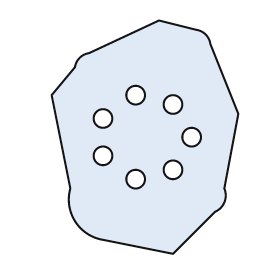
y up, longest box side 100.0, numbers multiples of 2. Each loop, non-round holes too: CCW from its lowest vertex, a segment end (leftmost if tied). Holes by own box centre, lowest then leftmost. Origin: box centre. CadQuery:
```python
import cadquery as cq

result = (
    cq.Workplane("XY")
    .moveTo(12.0, -50.0)
    .lineTo(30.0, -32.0)
    .threePointArc((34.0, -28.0), (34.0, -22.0))
    .lineTo(40.0, 10.0)
    .lineTo(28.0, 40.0)
    .threePointArc((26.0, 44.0), (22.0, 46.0))
    .lineTo(6.0, 50.0)
    .lineTo(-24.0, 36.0)
    .threePointArc((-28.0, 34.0), (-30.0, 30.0))
    .lineTo(-40.0, 18.0)
    .lineTo(-32.0, -22.0)
    .threePointArc((-30.0, -36.0), (-18.0, -44.0))
    .close()
    .moveTo(-4.0, -18.0)
    .circle(4.0)
    .moveTo(12.0, -14.0)
    .circle(4.0)
    .moveTo(-18.0, -8.0)
    .circle(4.0)
    .moveTo(20.0, 0.0)
    .circle(4.0)
    .moveTo(-18.0, 8.0)
    .circle(4.0)
    .moveTo(12.0, 14.0)
    .circle(4.0)
    .moveTo(-4.0, 18.0)
    .circle(4.0)
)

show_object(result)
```